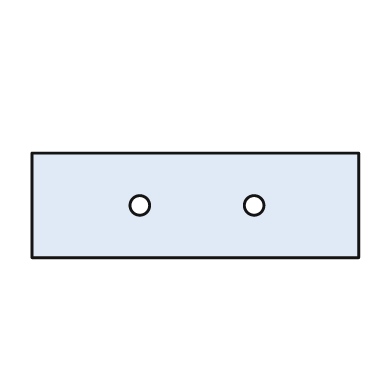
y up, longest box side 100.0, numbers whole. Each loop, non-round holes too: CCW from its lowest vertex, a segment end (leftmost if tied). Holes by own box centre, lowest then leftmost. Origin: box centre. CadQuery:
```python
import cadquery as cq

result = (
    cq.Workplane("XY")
    .moveTo(-50.0, -16.0)
    .lineTo(50.0, -16.0)
    .lineTo(50.0, 16.0)
    .lineTo(-50.0, 16.0)
    .close()
    .moveTo(-17.0, 0.0)
    .circle(3.0)
    .moveTo(18.0, 0.0)
    .circle(3.0)
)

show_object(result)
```